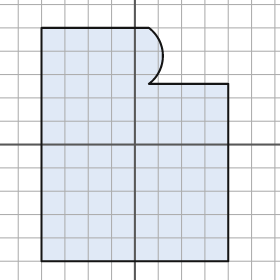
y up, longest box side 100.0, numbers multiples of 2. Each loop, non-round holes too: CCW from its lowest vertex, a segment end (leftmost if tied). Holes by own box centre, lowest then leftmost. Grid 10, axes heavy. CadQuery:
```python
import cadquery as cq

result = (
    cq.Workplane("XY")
    .moveTo(-40.0, -50.0)
    .lineTo(40.0, -50.0)
    .lineTo(40.0, 26.0)
    .lineTo(6.0, 26.0)
    .threePointArc((12.0, 38.0), (6.0, 50.0))
    .lineTo(-40.0, 50.0)
    .close()
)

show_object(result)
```